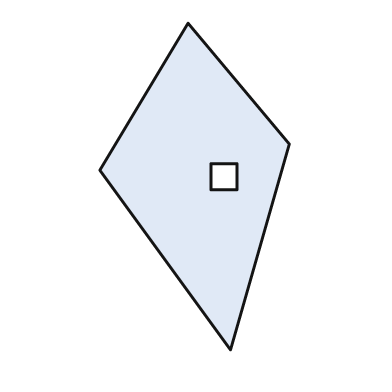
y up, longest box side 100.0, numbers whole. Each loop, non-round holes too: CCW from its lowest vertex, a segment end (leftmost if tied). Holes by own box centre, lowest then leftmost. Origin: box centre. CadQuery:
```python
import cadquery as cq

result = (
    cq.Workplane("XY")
    .moveTo(11.0, -50.0)
    .lineTo(29.0, 13.0)
    .lineTo(-2.0, 50.0)
    .lineTo(-29.0, 5.0)
    .close()
    .moveTo(5.0, -1.0)
    .lineTo(13.0, -1.0)
    .lineTo(13.0, 7.0)
    .lineTo(5.0, 7.0)
    .close()
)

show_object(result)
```